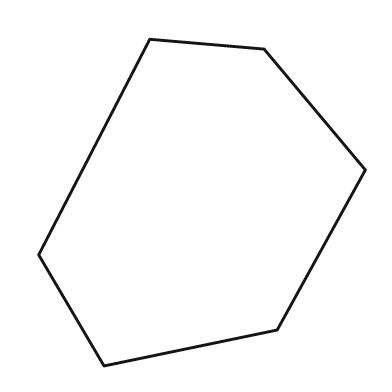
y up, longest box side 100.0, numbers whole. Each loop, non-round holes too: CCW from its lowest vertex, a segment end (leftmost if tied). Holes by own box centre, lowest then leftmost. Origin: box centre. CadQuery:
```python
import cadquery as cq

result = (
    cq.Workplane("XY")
    .moveTo(-30.0, -50.0)
    .lineTo(23.0, -39.0)
    .lineTo(50.0, 10.0)
    .lineTo(19.0, 47.0)
    .lineTo(-16.0, 50.0)
    .lineTo(-50.0, -16.0)
    .close()
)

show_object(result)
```